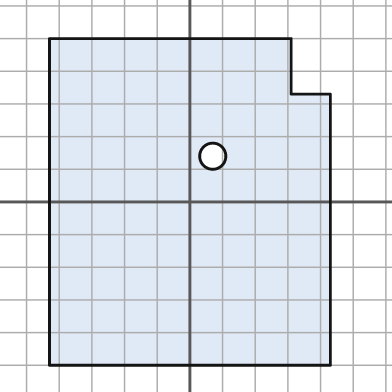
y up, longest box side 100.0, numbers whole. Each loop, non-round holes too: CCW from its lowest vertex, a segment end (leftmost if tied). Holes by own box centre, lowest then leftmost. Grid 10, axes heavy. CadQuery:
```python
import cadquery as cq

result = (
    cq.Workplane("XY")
    .moveTo(-43.0, -50.0)
    .lineTo(43.0, -50.0)
    .lineTo(43.0, 33.0)
    .lineTo(31.0, 33.0)
    .lineTo(31.0, 50.0)
    .lineTo(-43.0, 50.0)
    .close()
    .moveTo(7.0, 14.0)
    .circle(4.0)
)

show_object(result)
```